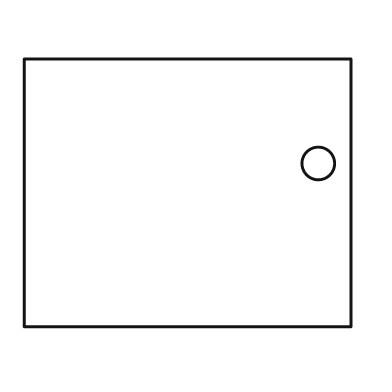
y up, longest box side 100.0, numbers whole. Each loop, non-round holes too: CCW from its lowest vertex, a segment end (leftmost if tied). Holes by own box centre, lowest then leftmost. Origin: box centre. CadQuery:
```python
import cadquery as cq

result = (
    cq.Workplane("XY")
    .moveTo(-50.0, -41.0)
    .lineTo(50.0, -41.0)
    .lineTo(50.0, 41.0)
    .lineTo(-50.0, 41.0)
    .close()
    .moveTo(40.0, 9.0)
    .circle(5.0)
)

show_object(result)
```